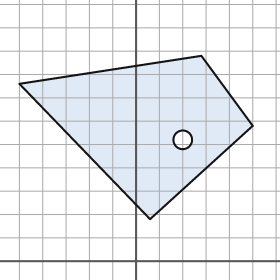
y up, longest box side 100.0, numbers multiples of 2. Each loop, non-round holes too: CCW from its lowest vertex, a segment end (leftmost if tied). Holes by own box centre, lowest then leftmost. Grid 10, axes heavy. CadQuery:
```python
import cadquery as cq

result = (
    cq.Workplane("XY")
    .moveTo(6.0, 18.0)
    .lineTo(50.0, 58.0)
    .lineTo(28.0, 88.0)
    .lineTo(-50.0, 76.0)
    .close()
    .moveTo(20.0, 52.0)
    .circle(4.0)
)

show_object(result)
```